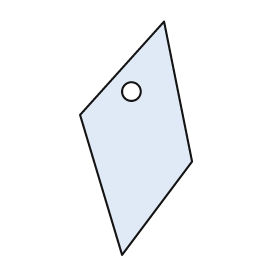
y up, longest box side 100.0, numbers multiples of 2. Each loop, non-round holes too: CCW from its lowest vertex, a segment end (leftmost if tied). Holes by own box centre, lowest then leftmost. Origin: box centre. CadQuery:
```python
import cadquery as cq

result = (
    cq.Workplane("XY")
    .moveTo(-6.0, -50.0)
    .lineTo(24.0, -10.0)
    .lineTo(12.0, 50.0)
    .lineTo(-24.0, 10.0)
    .close()
    .moveTo(-2.0, 20.0)
    .circle(4.0)
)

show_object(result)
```